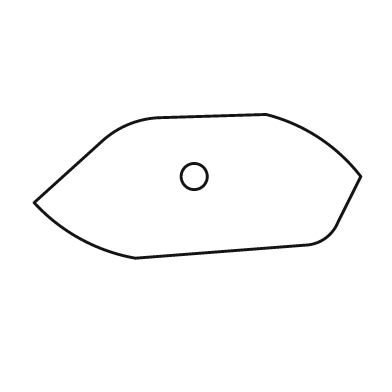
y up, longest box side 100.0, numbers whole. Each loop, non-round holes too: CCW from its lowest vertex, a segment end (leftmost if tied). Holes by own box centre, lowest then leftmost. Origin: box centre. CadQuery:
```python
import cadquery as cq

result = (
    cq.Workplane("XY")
    .moveTo(-19.0, -22.0)
    .lineTo(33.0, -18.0)
    .threePointArc((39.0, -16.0), (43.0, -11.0))
    .lineTo(50.0, 3.0)
    .threePointArc((37.0, 15.0), (21.0, 22.0))
    .lineTo(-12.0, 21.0)
    .threePointArc((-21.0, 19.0), (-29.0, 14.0))
    .lineTo(-50.0, -5.0)
    .threePointArc((-36.0, -16.0), (-19.0, -22.0))
    .close()
    .moveTo(-1.0, 3.0)
    .circle(4.0)
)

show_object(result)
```